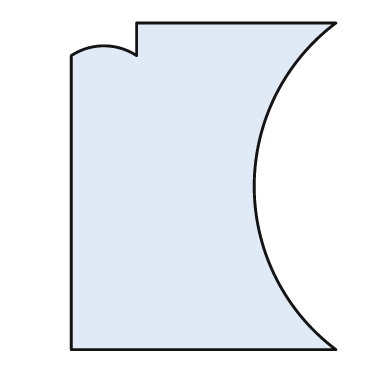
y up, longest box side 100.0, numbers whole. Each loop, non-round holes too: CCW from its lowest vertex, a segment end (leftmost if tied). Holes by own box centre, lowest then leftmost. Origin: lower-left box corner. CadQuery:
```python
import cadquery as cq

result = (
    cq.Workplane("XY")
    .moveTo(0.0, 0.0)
    .lineTo(81.0, 0.0)
    .threePointArc((56.0, 50.0), (81.0, 100.0))
    .lineTo(20.0, 100.0)
    .lineTo(20.0, 90.0)
    .threePointArc((10.0, 93.0), (0.0, 90.0))
    .close()
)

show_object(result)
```